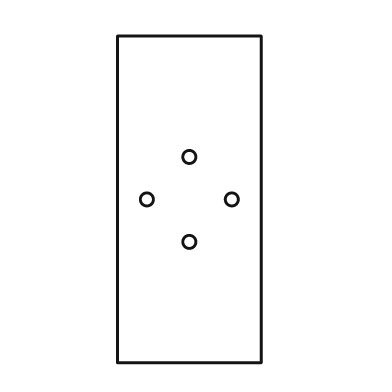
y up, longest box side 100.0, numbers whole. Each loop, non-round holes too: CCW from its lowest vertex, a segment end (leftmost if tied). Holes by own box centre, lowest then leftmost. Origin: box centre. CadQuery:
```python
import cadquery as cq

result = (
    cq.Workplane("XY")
    .moveTo(-22.0, -50.0)
    .lineTo(22.0, -50.0)
    .lineTo(22.0, 50.0)
    .lineTo(-22.0, 50.0)
    .close()
    .moveTo(0.0, -13.0)
    .circle(2.0)
    .moveTo(-13.0, 0.0)
    .circle(2.0)
    .moveTo(13.0, 0.0)
    .circle(2.0)
    .moveTo(0.0, 13.0)
    .circle(2.0)
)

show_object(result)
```